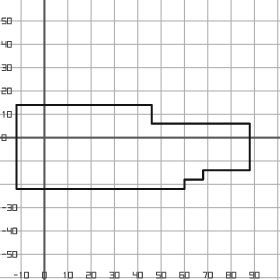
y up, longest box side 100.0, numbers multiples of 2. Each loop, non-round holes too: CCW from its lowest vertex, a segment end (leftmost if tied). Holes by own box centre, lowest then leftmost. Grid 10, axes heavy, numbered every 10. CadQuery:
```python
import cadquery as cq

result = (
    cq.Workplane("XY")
    .moveTo(-12.0, -22.0)
    .lineTo(60.0, -22.0)
    .lineTo(60.0, -18.0)
    .lineTo(68.0, -18.0)
    .lineTo(68.0, -14.0)
    .lineTo(88.0, -14.0)
    .lineTo(88.0, 6.0)
    .lineTo(46.0, 6.0)
    .lineTo(46.0, 14.0)
    .lineTo(-12.0, 14.0)
    .close()
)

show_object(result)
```